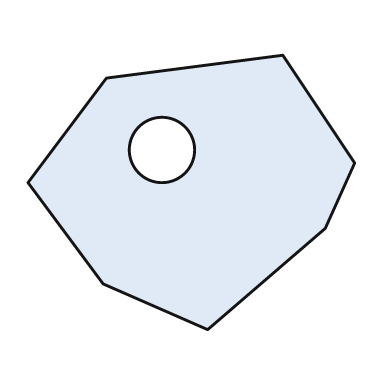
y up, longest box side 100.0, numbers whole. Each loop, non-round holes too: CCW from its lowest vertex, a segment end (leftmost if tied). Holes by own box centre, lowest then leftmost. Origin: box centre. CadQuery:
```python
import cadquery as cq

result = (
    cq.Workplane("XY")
    .moveTo(5.0, -42.0)
    .lineTo(41.0, -11.0)
    .lineTo(50.0, 9.0)
    .lineTo(28.0, 42.0)
    .lineTo(-26.0, 35.0)
    .lineTo(-50.0, 3.0)
    .lineTo(-27.0, -28.0)
    .close()
    .moveTo(-9.0, 13.0)
    .circle(10.0)
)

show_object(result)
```